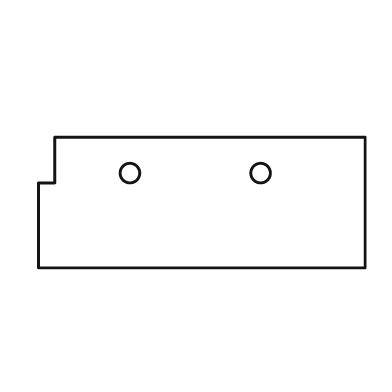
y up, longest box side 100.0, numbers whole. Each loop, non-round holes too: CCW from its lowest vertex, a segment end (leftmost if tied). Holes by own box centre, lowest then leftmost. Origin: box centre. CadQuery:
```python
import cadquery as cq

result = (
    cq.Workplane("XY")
    .moveTo(-50.0, -20.0)
    .lineTo(50.0, -20.0)
    .lineTo(50.0, 20.0)
    .lineTo(-45.0, 20.0)
    .lineTo(-45.0, 6.0)
    .lineTo(-50.0, 6.0)
    .close()
    .moveTo(-22.0, 9.0)
    .circle(3.0)
    .moveTo(18.0, 9.0)
    .circle(3.0)
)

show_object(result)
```